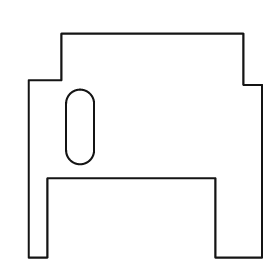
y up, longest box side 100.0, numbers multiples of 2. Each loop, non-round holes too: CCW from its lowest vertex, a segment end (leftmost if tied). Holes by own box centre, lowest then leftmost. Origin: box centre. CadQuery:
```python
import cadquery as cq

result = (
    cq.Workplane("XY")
    .moveTo(-50.0, -48.0)
    .lineTo(-42.0, -48.0)
    .lineTo(-42.0, -14.0)
    .lineTo(30.0, -14.0)
    .lineTo(30.0, -48.0)
    .lineTo(50.0, -48.0)
    .lineTo(50.0, 26.0)
    .lineTo(42.0, 26.0)
    .lineTo(42.0, 48.0)
    .lineTo(-36.0, 48.0)
    .lineTo(-36.0, 28.0)
    .lineTo(-50.0, 28.0)
    .close()
    .moveTo(-34.0, -2.0)
    .threePointArc((-28.0, -8.0), (-22.0, -2.0))
    .lineTo(-22.0, 18.0)
    .threePointArc((-28.0, 24.0), (-34.0, 18.0))
    .close()
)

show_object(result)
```